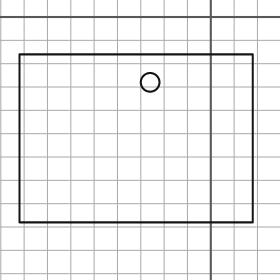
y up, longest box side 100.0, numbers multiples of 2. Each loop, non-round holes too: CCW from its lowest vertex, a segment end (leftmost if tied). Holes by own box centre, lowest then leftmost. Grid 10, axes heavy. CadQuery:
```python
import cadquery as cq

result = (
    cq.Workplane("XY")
    .moveTo(-82.0, -88.0)
    .lineTo(18.0, -88.0)
    .lineTo(18.0, -16.0)
    .lineTo(-82.0, -16.0)
    .close()
    .moveTo(-26.0, -28.0)
    .circle(4.0)
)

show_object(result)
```